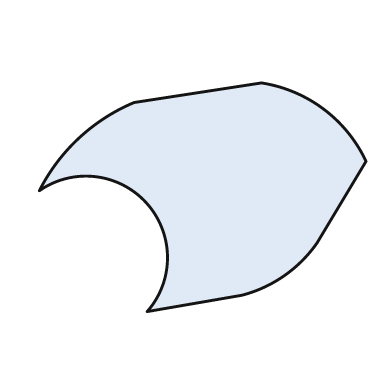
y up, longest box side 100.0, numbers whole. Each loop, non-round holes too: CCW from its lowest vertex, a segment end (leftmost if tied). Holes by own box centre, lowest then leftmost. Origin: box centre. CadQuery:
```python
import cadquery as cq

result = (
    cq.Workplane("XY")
    .moveTo(-17.0, -35.0)
    .lineTo(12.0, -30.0)
    .threePointArc((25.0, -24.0), (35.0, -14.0))
    .lineTo(50.0, 11.0)
    .threePointArc((37.0, 27.0), (18.0, 35.0))
    .lineTo(-21.0, 29.0)
    .threePointArc((-38.0, 18.0), (-50.0, 2.0))
    .threePointArc((-17.0, -2.0), (-17.0, -35.0))
    .close()
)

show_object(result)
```